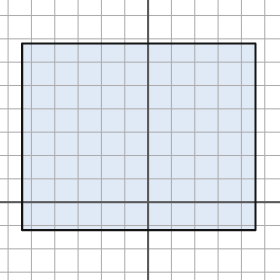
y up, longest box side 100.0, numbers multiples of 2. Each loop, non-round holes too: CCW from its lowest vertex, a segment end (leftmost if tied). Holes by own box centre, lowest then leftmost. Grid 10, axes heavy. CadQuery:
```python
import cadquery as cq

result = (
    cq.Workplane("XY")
    .moveTo(-54.0, -12.0)
    .lineTo(46.0, -12.0)
    .lineTo(46.0, 68.0)
    .lineTo(-54.0, 68.0)
    .close()
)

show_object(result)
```